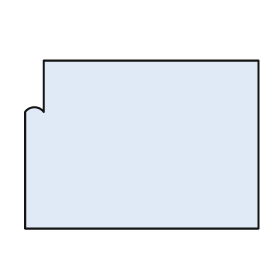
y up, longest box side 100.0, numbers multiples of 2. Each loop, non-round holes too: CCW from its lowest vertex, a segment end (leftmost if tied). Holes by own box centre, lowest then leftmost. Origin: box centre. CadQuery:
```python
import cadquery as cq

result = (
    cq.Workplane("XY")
    .moveTo(-50.0, -36.0)
    .lineTo(50.0, -36.0)
    .lineTo(50.0, 36.0)
    .lineTo(-42.0, 36.0)
    .lineTo(-42.0, 14.0)
    .threePointArc((-46.0, 16.0), (-50.0, 14.0))
    .close()
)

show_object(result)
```